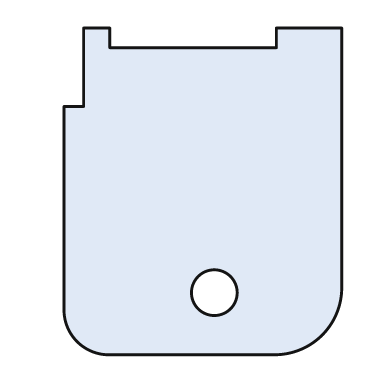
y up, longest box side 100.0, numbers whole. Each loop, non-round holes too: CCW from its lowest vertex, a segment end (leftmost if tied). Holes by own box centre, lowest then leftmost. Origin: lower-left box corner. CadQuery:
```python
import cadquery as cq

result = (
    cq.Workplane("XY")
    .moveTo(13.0, 0.0)
    .lineTo(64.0, 0.0)
    .threePointArc((79.0, 6.0), (85.0, 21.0))
    .lineTo(85.0, 100.0)
    .lineTo(65.0, 100.0)
    .lineTo(65.0, 94.0)
    .lineTo(14.0, 94.0)
    .lineTo(14.0, 100.0)
    .lineTo(6.0, 100.0)
    .lineTo(6.0, 76.0)
    .lineTo(0.0, 76.0)
    .lineTo(0.0, 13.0)
    .threePointArc((4.0, 4.0), (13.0, 0.0))
    .close()
    .moveTo(46.0, 19.0)
    .circle(7.0)
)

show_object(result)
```